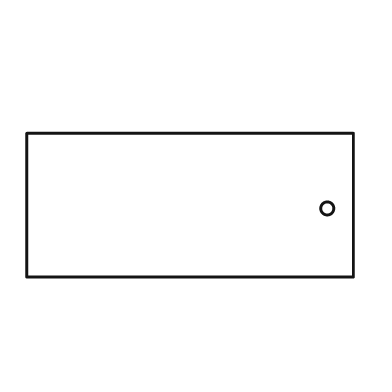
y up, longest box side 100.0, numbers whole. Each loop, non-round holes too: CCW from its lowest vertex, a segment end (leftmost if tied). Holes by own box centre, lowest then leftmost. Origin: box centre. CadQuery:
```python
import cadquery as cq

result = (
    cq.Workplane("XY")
    .moveTo(-50.0, -22.0)
    .lineTo(50.0, -22.0)
    .lineTo(50.0, 22.0)
    .lineTo(-50.0, 22.0)
    .close()
    .moveTo(42.0, -1.0)
    .circle(2.0)
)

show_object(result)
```